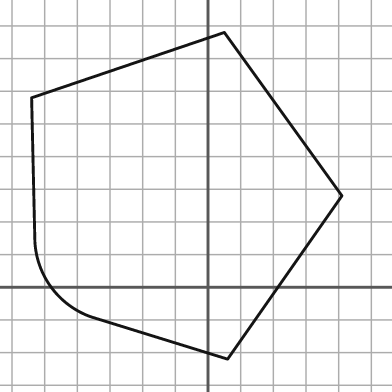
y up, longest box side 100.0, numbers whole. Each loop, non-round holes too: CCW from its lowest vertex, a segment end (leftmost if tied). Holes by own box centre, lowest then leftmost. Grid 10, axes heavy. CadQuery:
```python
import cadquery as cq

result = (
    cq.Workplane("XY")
    .moveTo(6.0, -22.0)
    .lineTo(41.0, 28.0)
    .lineTo(5.0, 78.0)
    .lineTo(-54.0, 58.0)
    .lineTo(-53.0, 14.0)
    .threePointArc((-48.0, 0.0), (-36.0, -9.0))
    .close()
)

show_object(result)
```